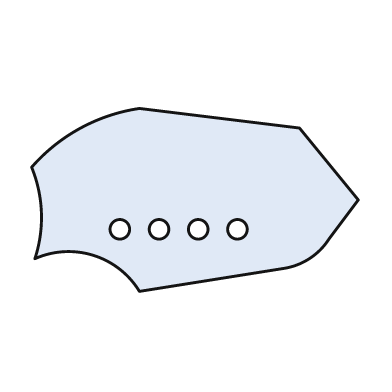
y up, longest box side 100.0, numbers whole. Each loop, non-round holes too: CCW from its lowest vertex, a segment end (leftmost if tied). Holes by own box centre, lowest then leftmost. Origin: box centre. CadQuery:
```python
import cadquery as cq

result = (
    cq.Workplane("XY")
    .moveTo(-17.0, -28.0)
    .lineTo(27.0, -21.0)
    .threePointArc((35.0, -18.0), (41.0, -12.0))
    .lineTo(50.0, 0.0)
    .lineTo(32.0, 22.0)
    .lineTo(-17.0, 28.0)
    .threePointArc((-35.0, 22.0), (-50.0, 10.0))
    .threePointArc((-47.0, -4.0), (-49.0, -18.0))
    .threePointArc((-31.0, -17.0), (-17.0, -28.0))
    .close()
    .moveTo(-23.0, -9.0)
    .circle(3.0)
    .moveTo(-11.0, -9.0)
    .circle(3.0)
    .moveTo(1.0, -9.0)
    .circle(3.0)
    .moveTo(13.0, -9.0)
    .circle(3.0)
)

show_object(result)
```